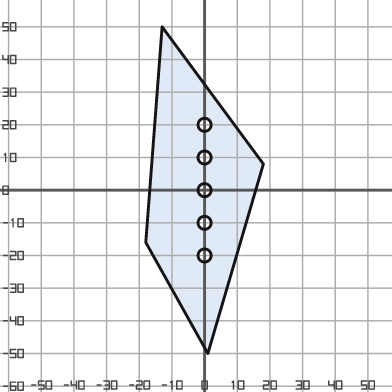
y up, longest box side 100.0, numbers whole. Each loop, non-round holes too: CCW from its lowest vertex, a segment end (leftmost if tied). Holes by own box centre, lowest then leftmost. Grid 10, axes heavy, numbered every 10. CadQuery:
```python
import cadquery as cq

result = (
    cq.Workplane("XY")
    .moveTo(1.0, -50.0)
    .lineTo(18.0, 8.0)
    .lineTo(-13.0, 50.0)
    .lineTo(-18.0, -16.0)
    .close()
    .moveTo(0.0, -20.0)
    .circle(2.0)
    .moveTo(0.0, -10.0)
    .circle(2.0)
    .moveTo(0.0, 0.0)
    .circle(2.0)
    .moveTo(0.0, 10.0)
    .circle(2.0)
    .moveTo(0.0, 20.0)
    .circle(2.0)
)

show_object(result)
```